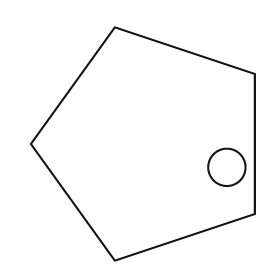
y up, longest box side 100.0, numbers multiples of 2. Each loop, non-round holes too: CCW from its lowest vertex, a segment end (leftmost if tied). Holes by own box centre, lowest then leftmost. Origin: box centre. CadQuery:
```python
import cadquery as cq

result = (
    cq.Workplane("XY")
    .moveTo(-12.0, -50.0)
    .lineTo(48.0, -30.0)
    .lineTo(48.0, 30.0)
    .lineTo(-12.0, 50.0)
    .lineTo(-48.0, 0.0)
    .close()
    .moveTo(36.0, -10.0)
    .circle(8.0)
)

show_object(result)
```